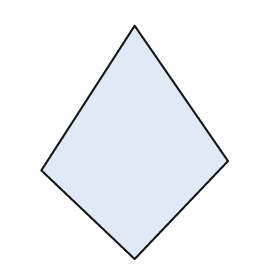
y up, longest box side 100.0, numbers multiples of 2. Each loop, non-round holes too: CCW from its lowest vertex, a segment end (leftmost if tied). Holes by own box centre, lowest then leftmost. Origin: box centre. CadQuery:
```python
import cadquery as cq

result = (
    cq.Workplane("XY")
    .moveTo(0.0, -50.0)
    .lineTo(40.0, -8.0)
    .lineTo(0.0, 50.0)
    .lineTo(-40.0, -12.0)
    .close()
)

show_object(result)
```